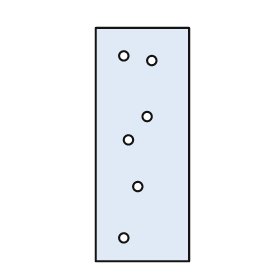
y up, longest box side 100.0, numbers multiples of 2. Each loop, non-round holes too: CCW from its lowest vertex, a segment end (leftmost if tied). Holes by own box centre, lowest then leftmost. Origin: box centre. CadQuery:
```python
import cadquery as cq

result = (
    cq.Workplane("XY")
    .moveTo(-20.0, -50.0)
    .lineTo(20.0, -50.0)
    .lineTo(20.0, 50.0)
    .lineTo(-20.0, 50.0)
    .close()
    .moveTo(-8.0, -40.0)
    .circle(2.0)
    .moveTo(-2.0, -18.0)
    .circle(2.0)
    .moveTo(-6.0, 2.0)
    .circle(2.0)
    .moveTo(2.0, 12.0)
    .circle(2.0)
    .moveTo(4.0, 36.0)
    .circle(2.0)
    .moveTo(-8.0, 38.0)
    .circle(2.0)
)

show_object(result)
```